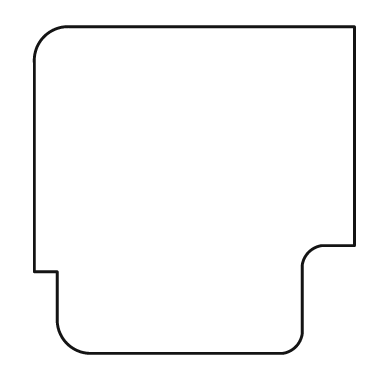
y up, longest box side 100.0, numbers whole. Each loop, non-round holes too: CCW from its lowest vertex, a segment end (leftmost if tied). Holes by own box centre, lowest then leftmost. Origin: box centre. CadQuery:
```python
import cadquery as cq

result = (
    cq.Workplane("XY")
    .moveTo(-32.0, -50.0)
    .lineTo(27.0, -50.0)
    .threePointArc((31.0, -48.0), (33.0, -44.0))
    .lineTo(33.0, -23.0)
    .threePointArc((35.0, -19.0), (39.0, -17.0))
    .lineTo(49.0, -17.0)
    .lineTo(49.0, 50.0)
    .lineTo(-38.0, 50.0)
    .threePointArc((-46.0, 47.0), (-49.0, 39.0))
    .lineTo(-49.0, -25.0)
    .lineTo(-42.0, -25.0)
    .lineTo(-42.0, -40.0)
    .threePointArc((-39.0, -47.0), (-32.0, -50.0))
    .close()
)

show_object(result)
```